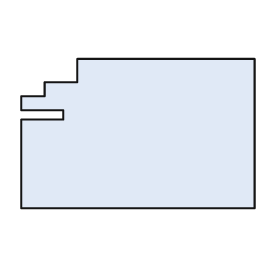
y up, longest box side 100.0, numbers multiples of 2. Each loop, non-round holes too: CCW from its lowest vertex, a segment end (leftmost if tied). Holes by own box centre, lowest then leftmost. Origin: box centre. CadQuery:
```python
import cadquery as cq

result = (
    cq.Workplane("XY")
    .moveTo(-50.0, -32.0)
    .lineTo(50.0, -32.0)
    .lineTo(50.0, 32.0)
    .lineTo(-26.0, 32.0)
    .lineTo(-26.0, 22.0)
    .lineTo(-40.0, 22.0)
    .lineTo(-40.0, 16.0)
    .lineTo(-50.0, 16.0)
    .lineTo(-50.0, 10.0)
    .lineTo(-32.0, 10.0)
    .lineTo(-32.0, 6.0)
    .lineTo(-50.0, 6.0)
    .close()
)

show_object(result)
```